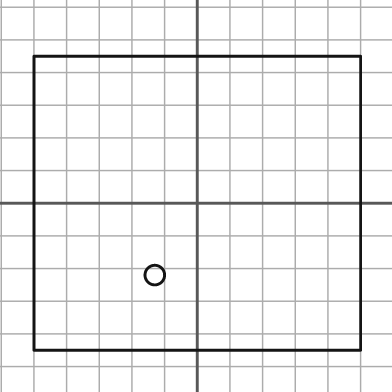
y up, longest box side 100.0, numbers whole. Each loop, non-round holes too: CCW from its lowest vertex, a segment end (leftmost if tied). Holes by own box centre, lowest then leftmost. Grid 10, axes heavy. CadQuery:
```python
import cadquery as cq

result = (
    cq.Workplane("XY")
    .moveTo(-50.0, -45.0)
    .lineTo(50.0, -45.0)
    .lineTo(50.0, 45.0)
    .lineTo(-50.0, 45.0)
    .close()
    .moveTo(-13.0, -22.0)
    .circle(3.0)
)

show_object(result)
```